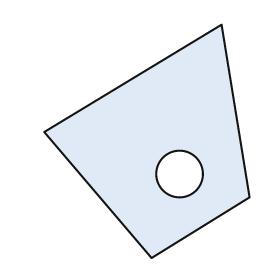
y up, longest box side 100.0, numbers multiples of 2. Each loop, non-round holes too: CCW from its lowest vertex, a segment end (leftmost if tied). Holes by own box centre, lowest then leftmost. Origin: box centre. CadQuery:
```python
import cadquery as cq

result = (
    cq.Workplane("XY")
    .moveTo(2.0, -50.0)
    .lineTo(44.0, -24.0)
    .lineTo(32.0, 50.0)
    .lineTo(-44.0, 4.0)
    .close()
    .moveTo(14.0, -14.0)
    .circle(10.0)
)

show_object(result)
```